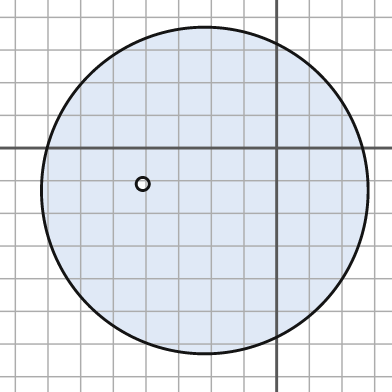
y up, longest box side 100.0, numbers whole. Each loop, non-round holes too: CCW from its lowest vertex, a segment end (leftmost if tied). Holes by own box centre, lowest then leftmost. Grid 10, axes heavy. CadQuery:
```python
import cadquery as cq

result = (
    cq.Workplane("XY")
    .moveTo(-22.0, -13.0)
    .circle(50.0)
    .moveTo(-41.0, -11.0)
    .circle(2.0)
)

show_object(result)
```